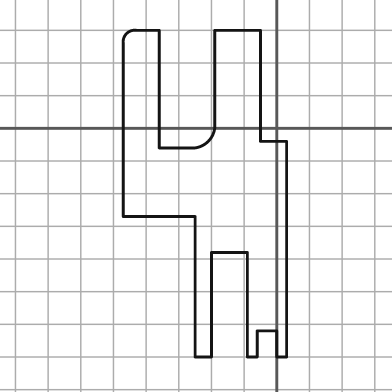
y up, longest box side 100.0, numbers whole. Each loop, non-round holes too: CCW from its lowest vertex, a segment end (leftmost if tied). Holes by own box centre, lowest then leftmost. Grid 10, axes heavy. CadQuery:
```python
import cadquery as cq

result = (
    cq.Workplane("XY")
    .moveTo(-25.0, -70.0)
    .lineTo(-20.0, -70.0)
    .lineTo(-20.0, -38.0)
    .lineTo(-9.0, -38.0)
    .lineTo(-9.0, -70.0)
    .lineTo(-6.0, -70.0)
    .lineTo(-6.0, -62.0)
    .lineTo(0.0, -62.0)
    .lineTo(0.0, -70.0)
    .lineTo(3.0, -70.0)
    .lineTo(3.0, -4.0)
    .lineTo(-5.0, -4.0)
    .lineTo(-5.0, 30.0)
    .lineTo(-19.0, 30.0)
    .lineTo(-19.0, 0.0)
    .threePointArc((-21.0, -4.0), (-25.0, -6.0))
    .lineTo(-36.0, -6.0)
    .lineTo(-36.0, 30.0)
    .lineTo(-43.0, 30.0)
    .threePointArc((-46.0, 29.0), (-47.0, 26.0))
    .lineTo(-47.0, -27.0)
    .lineTo(-25.0, -27.0)
    .close()
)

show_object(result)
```